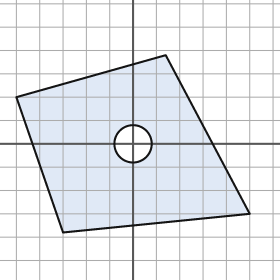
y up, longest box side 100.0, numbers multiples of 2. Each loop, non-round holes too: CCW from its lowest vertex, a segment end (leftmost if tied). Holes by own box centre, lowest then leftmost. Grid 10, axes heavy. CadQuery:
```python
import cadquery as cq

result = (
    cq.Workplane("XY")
    .moveTo(-30.0, -38.0)
    .lineTo(50.0, -30.0)
    .lineTo(14.0, 38.0)
    .lineTo(-50.0, 20.0)
    .close()
    .moveTo(0.0, 0.0)
    .circle(8.0)
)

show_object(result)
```